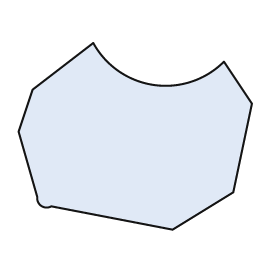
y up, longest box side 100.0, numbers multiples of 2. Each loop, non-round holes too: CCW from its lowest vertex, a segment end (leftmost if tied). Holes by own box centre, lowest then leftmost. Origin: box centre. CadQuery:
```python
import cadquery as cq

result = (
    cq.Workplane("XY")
    .moveTo(16.0, -40.0)
    .lineTo(42.0, -24.0)
    .lineTo(50.0, 14.0)
    .lineTo(38.0, 32.0)
    .threePointArc((8.0, 22.0), (-18.0, 40.0))
    .lineTo(-44.0, 20.0)
    .lineTo(-50.0, 2.0)
    .lineTo(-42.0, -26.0)
    .threePointArc((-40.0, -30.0), (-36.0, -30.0))
    .close()
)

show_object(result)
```